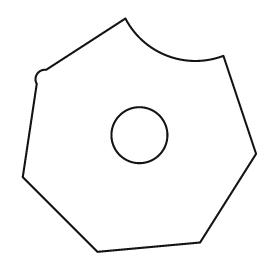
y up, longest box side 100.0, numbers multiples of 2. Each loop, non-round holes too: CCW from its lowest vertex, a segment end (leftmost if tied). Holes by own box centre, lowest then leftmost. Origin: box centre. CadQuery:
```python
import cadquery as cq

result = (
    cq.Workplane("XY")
    .moveTo(-18.0, -50.0)
    .lineTo(26.0, -46.0)
    .lineTo(50.0, -8.0)
    .lineTo(36.0, 34.0)
    .threePointArc((12.0, 34.0), (-6.0, 50.0))
    .lineTo(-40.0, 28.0)
    .threePointArc((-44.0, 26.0), (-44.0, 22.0))
    .lineTo(-50.0, -18.0)
    .close()
    .moveTo(0.0, 0.0)
    .circle(12.0)
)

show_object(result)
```